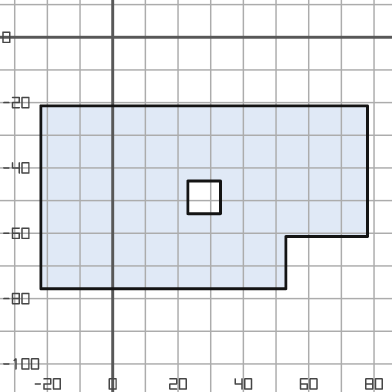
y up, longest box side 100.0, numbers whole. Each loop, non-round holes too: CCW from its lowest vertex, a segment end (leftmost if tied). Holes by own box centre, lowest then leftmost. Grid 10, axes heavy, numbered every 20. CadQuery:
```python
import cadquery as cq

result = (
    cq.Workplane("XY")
    .moveTo(-22.0, -77.0)
    .lineTo(53.0, -77.0)
    .lineTo(53.0, -61.0)
    .lineTo(78.0, -61.0)
    .lineTo(78.0, -21.0)
    .lineTo(-22.0, -21.0)
    .close()
    .moveTo(23.0, -54.0)
    .lineTo(33.0, -54.0)
    .lineTo(33.0, -44.0)
    .lineTo(23.0, -44.0)
    .close()
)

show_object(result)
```